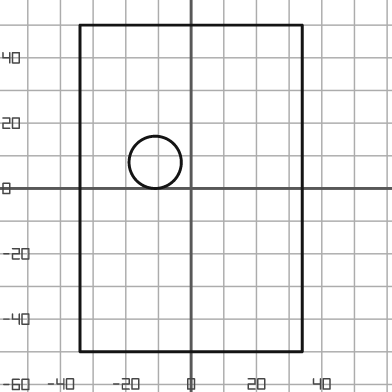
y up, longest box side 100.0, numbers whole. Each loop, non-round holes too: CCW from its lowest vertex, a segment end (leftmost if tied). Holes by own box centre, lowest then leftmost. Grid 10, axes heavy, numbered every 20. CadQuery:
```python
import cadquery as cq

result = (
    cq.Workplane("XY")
    .moveTo(-34.0, -50.0)
    .lineTo(34.0, -50.0)
    .lineTo(34.0, 50.0)
    .lineTo(-34.0, 50.0)
    .close()
    .moveTo(-11.0, 8.0)
    .circle(8.0)
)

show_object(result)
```